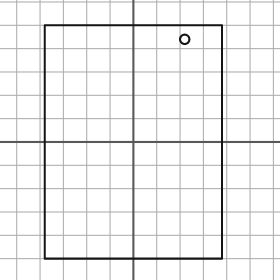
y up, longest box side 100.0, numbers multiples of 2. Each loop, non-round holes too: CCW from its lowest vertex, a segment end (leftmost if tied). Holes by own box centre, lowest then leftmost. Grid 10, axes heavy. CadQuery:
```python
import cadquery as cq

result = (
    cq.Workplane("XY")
    .moveTo(-38.0, -50.0)
    .lineTo(38.0, -50.0)
    .lineTo(38.0, 50.0)
    .lineTo(-38.0, 50.0)
    .close()
    .moveTo(22.0, 44.0)
    .circle(2.0)
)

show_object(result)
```